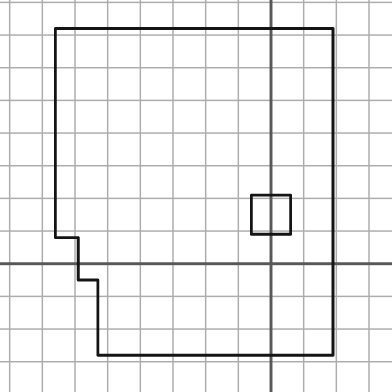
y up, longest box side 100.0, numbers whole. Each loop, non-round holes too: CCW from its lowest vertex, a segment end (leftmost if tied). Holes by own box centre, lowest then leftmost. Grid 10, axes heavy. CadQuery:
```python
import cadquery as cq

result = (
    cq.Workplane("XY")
    .moveTo(-53.0, -28.0)
    .lineTo(19.0, -28.0)
    .lineTo(19.0, 72.0)
    .lineTo(-66.0, 72.0)
    .lineTo(-66.0, 8.0)
    .lineTo(-59.0, 8.0)
    .lineTo(-59.0, -5.0)
    .lineTo(-53.0, -5.0)
    .close()
    .moveTo(-6.0, 9.0)
    .lineTo(6.0, 9.0)
    .lineTo(6.0, 21.0)
    .lineTo(-6.0, 21.0)
    .close()
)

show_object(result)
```